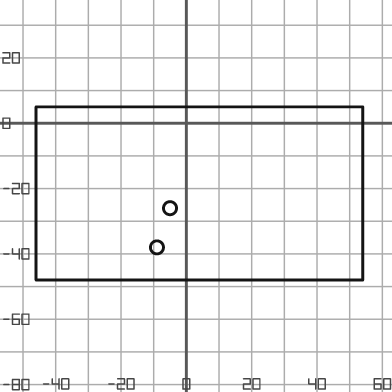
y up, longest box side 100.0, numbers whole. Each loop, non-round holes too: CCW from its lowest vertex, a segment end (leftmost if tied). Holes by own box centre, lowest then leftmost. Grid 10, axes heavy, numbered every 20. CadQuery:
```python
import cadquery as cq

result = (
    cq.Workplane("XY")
    .moveTo(-46.0, -48.0)
    .lineTo(54.0, -48.0)
    .lineTo(54.0, 5.0)
    .lineTo(-46.0, 5.0)
    .close()
    .moveTo(-9.0, -38.0)
    .circle(2.0)
    .moveTo(-5.0, -26.0)
    .circle(2.0)
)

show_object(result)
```